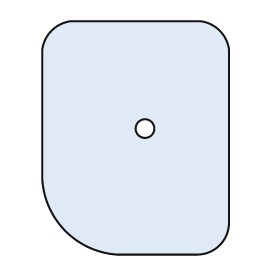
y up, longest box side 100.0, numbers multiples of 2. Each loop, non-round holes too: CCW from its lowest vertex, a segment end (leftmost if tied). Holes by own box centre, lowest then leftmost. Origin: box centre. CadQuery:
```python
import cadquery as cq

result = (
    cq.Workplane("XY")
    .moveTo(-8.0, -50.0)
    .lineTo(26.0, -50.0)
    .threePointArc((36.0, -46.0), (40.0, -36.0))
    .lineTo(40.0, 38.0)
    .threePointArc((36.0, 46.0), (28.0, 50.0))
    .lineTo(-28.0, 50.0)
    .threePointArc((-36.0, 46.0), (-40.0, 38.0))
    .lineTo(-40.0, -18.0)
    .threePointArc((-30.0, -40.0), (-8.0, -50.0))
    .close()
    .moveTo(4.0, 4.0)
    .circle(4.0)
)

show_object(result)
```